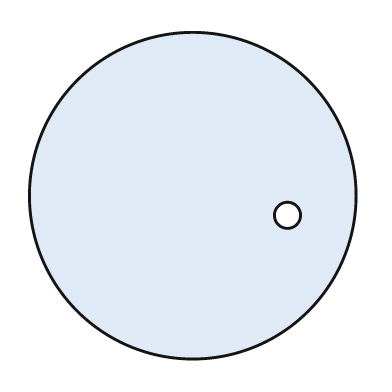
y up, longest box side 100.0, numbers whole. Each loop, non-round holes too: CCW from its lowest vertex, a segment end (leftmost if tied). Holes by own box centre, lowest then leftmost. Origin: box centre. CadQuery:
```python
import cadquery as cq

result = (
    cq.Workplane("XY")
    .moveTo(0.0, 0.0)
    .circle(50.0)
    .moveTo(29.0, -6.0)
    .circle(4.0)
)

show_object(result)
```